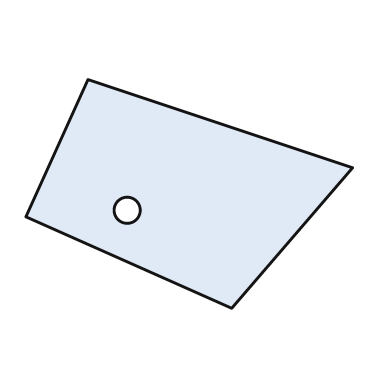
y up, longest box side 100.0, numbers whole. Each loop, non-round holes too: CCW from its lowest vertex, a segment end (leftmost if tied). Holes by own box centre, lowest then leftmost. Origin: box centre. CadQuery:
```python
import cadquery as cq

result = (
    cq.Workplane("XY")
    .moveTo(13.0, -35.0)
    .lineTo(50.0, 8.0)
    .lineTo(-31.0, 35.0)
    .lineTo(-50.0, -7.0)
    .close()
    .moveTo(-19.0, -5.0)
    .circle(4.0)
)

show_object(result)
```